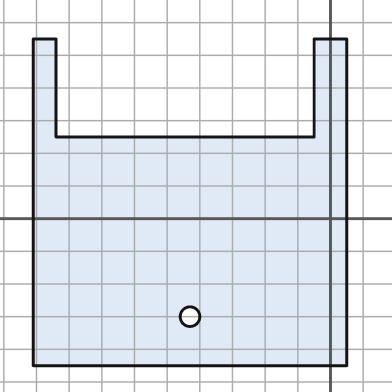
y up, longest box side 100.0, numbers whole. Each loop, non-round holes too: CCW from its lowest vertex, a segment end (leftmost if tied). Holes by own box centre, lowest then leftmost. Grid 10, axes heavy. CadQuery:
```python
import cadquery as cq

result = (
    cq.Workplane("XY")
    .moveTo(-91.0, -45.0)
    .lineTo(5.0, -45.0)
    .lineTo(5.0, 55.0)
    .lineTo(-5.0, 55.0)
    .lineTo(-5.0, 25.0)
    .lineTo(-84.0, 25.0)
    .lineTo(-84.0, 55.0)
    .lineTo(-91.0, 55.0)
    .close()
    .moveTo(-43.0, -30.0)
    .circle(3.0)
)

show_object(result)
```